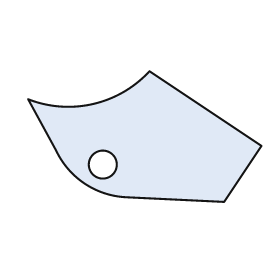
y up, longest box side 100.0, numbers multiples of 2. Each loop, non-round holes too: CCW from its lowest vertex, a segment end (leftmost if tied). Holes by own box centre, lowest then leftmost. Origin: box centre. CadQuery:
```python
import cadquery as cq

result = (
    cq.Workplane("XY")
    .moveTo(34.0, -28.0)
    .lineTo(50.0, -4.0)
    .lineTo(2.0, 28.0)
    .threePointArc((-22.0, 14.0), (-50.0, 16.0))
    .lineTo(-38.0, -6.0)
    .threePointArc((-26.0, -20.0), (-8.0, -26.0))
    .close()
    .moveTo(-18.0, -12.0)
    .circle(6.0)
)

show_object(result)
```